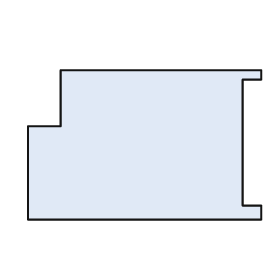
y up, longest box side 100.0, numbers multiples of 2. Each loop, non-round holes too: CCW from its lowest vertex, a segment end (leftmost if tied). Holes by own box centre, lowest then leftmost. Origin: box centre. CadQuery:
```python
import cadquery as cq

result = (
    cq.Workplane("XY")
    .moveTo(-50.0, -32.0)
    .lineTo(50.0, -32.0)
    .lineTo(50.0, -26.0)
    .lineTo(42.0, -26.0)
    .lineTo(42.0, 28.0)
    .lineTo(50.0, 28.0)
    .lineTo(50.0, 32.0)
    .lineTo(-36.0, 32.0)
    .lineTo(-36.0, 8.0)
    .lineTo(-50.0, 8.0)
    .close()
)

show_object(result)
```